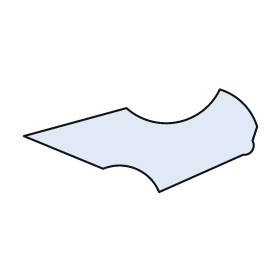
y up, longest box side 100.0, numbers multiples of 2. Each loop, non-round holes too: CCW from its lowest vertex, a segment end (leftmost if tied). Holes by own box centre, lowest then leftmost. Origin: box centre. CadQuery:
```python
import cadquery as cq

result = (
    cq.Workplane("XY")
    .moveTo(8.0, -22.0)
    .lineTo(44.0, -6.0)
    .threePointArc((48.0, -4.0), (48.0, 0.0))
    .lineTo(50.0, 6.0)
    .threePointArc((44.0, 16.0), (34.0, 22.0))
    .threePointArc((16.0, 8.0), (-6.0, 14.0))
    .lineTo(-50.0, 2.0)
    .lineTo(-16.0, -12.0)
    .threePointArc((-2.0, -12.0), (8.0, -22.0))
    .close()
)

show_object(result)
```